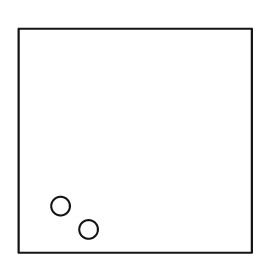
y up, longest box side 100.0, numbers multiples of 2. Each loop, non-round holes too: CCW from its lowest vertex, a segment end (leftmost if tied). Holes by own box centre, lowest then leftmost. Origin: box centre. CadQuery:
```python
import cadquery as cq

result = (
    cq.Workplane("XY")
    .moveTo(-50.0, -48.0)
    .lineTo(50.0, -48.0)
    .lineTo(50.0, 48.0)
    .lineTo(-50.0, 48.0)
    .close()
    .moveTo(-20.0, -38.0)
    .circle(4.0)
    .moveTo(-32.0, -28.0)
    .circle(4.0)
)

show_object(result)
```